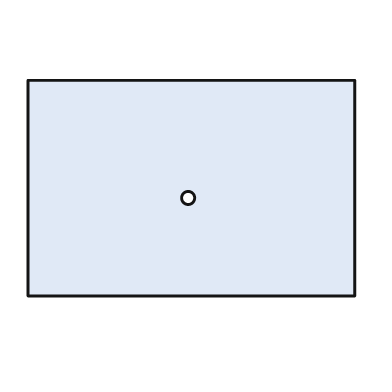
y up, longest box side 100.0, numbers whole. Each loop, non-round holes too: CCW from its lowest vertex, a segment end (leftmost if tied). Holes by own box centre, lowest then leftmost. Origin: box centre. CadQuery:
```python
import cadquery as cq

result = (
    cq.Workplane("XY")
    .moveTo(-50.0, -33.0)
    .lineTo(50.0, -33.0)
    .lineTo(50.0, 33.0)
    .lineTo(-50.0, 33.0)
    .close()
    .moveTo(-1.0, -3.0)
    .circle(2.0)
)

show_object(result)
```